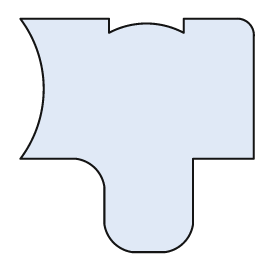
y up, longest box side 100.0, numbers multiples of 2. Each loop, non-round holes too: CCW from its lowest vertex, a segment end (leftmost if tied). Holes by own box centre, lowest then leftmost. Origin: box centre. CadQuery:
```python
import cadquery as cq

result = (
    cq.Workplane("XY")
    .moveTo(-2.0, -50.0)
    .lineTo(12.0, -50.0)
    .threePointArc((20.0, -46.0), (24.0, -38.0))
    .lineTo(24.0, -10.0)
    .lineTo(50.0, -10.0)
    .lineTo(50.0, 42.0)
    .threePointArc((48.0, 48.0), (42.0, 50.0))
    .lineTo(20.0, 50.0)
    .lineTo(20.0, 44.0)
    .threePointArc((4.0, 48.0), (-12.0, 44.0))
    .lineTo(-12.0, 50.0)
    .lineTo(-50.0, 50.0)
    .threePointArc((-40.0, 20.0), (-50.0, -10.0))
    .lineTo(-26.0, -10.0)
    .threePointArc((-18.0, -14.0), (-14.0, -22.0))
    .lineTo(-14.0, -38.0)
    .threePointArc((-10.0, -46.0), (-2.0, -50.0))
    .close()
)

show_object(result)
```